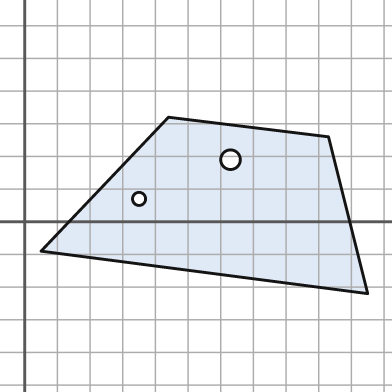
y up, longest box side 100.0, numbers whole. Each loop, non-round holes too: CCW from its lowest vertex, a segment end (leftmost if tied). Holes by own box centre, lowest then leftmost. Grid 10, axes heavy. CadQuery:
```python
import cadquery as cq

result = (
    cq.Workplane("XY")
    .moveTo(105.0, -22.0)
    .lineTo(93.0, 26.0)
    .lineTo(44.0, 32.0)
    .lineTo(5.0, -9.0)
    .close()
    .moveTo(35.0, 7.0)
    .circle(2.0)
    .moveTo(63.0, 19.0)
    .circle(3.0)
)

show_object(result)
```